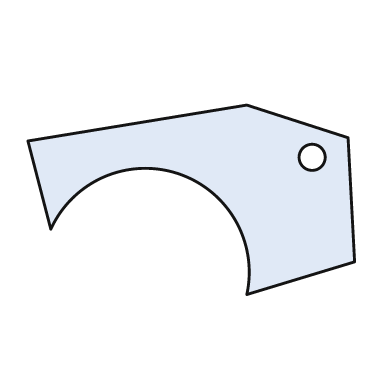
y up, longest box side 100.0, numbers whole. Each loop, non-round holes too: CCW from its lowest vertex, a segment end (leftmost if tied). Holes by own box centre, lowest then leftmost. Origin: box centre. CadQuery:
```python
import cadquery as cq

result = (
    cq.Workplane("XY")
    .moveTo(17.0, -29.0)
    .lineTo(50.0, -19.0)
    .lineTo(48.0, 19.0)
    .lineTo(17.0, 29.0)
    .lineTo(-50.0, 18.0)
    .lineTo(-43.0, -9.0)
    .threePointArc((-4.0, 8.0), (17.0, -29.0))
    .close()
    .moveTo(37.0, 13.0)
    .circle(4.0)
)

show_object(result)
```